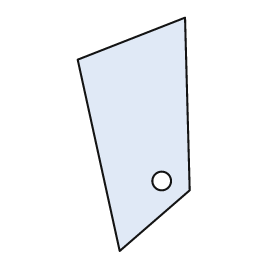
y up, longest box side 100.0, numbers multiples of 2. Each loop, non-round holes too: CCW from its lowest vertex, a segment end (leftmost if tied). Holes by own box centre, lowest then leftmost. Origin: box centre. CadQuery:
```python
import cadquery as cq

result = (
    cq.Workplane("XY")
    .moveTo(-6.0, -50.0)
    .lineTo(24.0, -24.0)
    .lineTo(22.0, 50.0)
    .lineTo(-24.0, 32.0)
    .close()
    .moveTo(12.0, -20.0)
    .circle(4.0)
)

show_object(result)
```